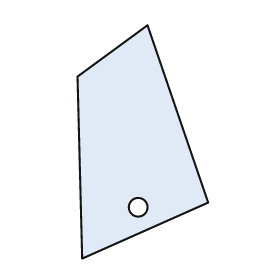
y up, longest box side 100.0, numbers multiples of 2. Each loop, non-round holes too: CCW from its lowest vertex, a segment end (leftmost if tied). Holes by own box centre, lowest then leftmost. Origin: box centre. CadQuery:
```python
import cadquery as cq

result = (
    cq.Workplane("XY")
    .moveTo(-26.0, -50.0)
    .lineTo(28.0, -26.0)
    .lineTo(2.0, 50.0)
    .lineTo(-28.0, 28.0)
    .close()
    .moveTo(-2.0, -28.0)
    .circle(4.0)
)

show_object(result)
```